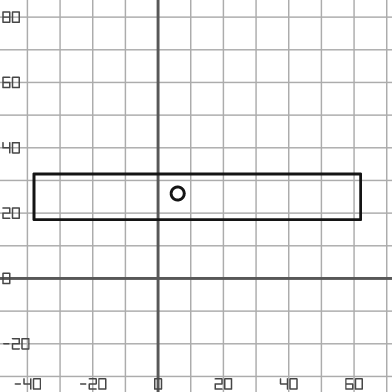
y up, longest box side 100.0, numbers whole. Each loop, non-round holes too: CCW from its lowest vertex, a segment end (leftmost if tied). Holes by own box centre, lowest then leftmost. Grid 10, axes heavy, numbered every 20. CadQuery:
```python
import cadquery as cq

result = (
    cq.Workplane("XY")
    .moveTo(-38.0, 18.0)
    .lineTo(62.0, 18.0)
    .lineTo(62.0, 32.0)
    .lineTo(-38.0, 32.0)
    .close()
    .moveTo(6.0, 26.0)
    .circle(2.0)
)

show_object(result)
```